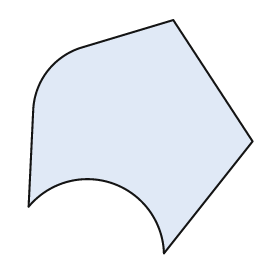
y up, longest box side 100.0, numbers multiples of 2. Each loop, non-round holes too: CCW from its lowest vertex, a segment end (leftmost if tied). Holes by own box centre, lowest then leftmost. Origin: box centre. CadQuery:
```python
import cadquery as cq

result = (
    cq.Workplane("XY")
    .moveTo(10.0, -50.0)
    .lineTo(48.0, -2.0)
    .lineTo(14.0, 50.0)
    .lineTo(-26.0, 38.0)
    .threePointArc((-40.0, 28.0), (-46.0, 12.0))
    .lineTo(-48.0, -30.0)
    .threePointArc((-12.0, -20.0), (10.0, -50.0))
    .close()
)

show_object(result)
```